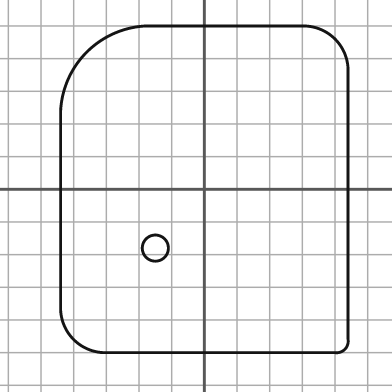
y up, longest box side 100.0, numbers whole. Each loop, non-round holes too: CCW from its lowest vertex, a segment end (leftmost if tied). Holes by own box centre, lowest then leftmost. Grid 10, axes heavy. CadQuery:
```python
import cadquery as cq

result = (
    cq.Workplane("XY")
    .moveTo(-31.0, -50.0)
    .lineTo(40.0, -50.0)
    .threePointArc((43.0, -49.0), (44.0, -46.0))
    .lineTo(44.0, 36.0)
    .threePointArc((40.0, 46.0), (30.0, 50.0))
    .lineTo(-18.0, 50.0)
    .threePointArc((-36.0, 42.0), (-44.0, 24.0))
    .lineTo(-44.0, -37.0)
    .threePointArc((-40.0, -46.0), (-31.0, -50.0))
    .close()
    .moveTo(-15.0, -18.0)
    .circle(4.0)
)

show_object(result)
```